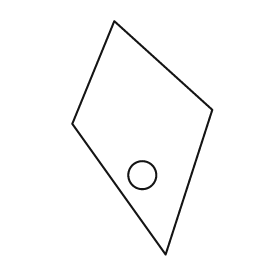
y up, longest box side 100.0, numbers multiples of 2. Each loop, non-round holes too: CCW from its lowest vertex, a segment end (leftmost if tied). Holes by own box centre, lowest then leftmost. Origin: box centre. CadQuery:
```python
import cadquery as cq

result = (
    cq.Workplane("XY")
    .moveTo(10.0, -50.0)
    .lineTo(30.0, 12.0)
    .lineTo(-12.0, 50.0)
    .lineTo(-30.0, 6.0)
    .close()
    .moveTo(0.0, -16.0)
    .circle(6.0)
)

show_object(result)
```